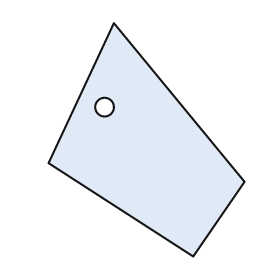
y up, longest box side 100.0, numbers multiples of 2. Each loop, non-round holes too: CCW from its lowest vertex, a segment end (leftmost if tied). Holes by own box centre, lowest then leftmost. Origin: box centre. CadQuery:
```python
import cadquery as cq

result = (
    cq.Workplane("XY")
    .moveTo(20.0, -50.0)
    .lineTo(42.0, -18.0)
    .lineTo(-14.0, 50.0)
    .lineTo(-42.0, -10.0)
    .close()
    .moveTo(-18.0, 14.0)
    .circle(4.0)
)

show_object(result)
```